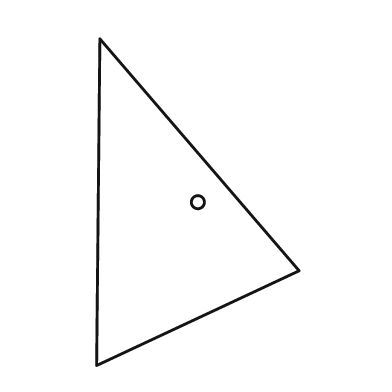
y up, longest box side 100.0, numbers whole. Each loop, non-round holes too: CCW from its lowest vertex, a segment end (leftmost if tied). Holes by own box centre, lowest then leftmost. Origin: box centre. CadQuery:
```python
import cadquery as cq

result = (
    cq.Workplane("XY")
    .moveTo(-31.0, -50.0)
    .lineTo(31.0, -21.0)
    .lineTo(-30.0, 50.0)
    .close()
    .moveTo(0.0, 0.0)
    .circle(2.0)
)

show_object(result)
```